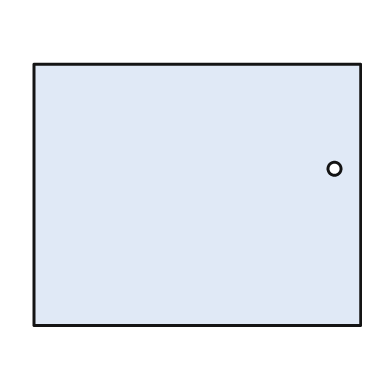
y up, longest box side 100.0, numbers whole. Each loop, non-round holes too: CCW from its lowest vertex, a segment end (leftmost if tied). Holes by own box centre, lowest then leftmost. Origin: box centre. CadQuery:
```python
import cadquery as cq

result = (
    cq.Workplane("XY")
    .moveTo(-50.0, -40.0)
    .lineTo(50.0, -40.0)
    .lineTo(50.0, 40.0)
    .lineTo(-50.0, 40.0)
    .close()
    .moveTo(42.0, 8.0)
    .circle(2.0)
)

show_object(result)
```